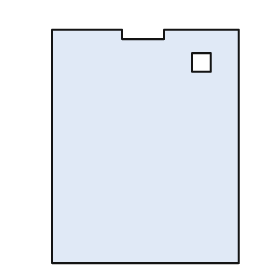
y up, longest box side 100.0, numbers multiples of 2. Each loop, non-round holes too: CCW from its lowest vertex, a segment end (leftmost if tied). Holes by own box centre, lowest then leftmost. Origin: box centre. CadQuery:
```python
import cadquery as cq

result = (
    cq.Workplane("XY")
    .moveTo(-40.0, -50.0)
    .lineTo(40.0, -50.0)
    .lineTo(40.0, 50.0)
    .lineTo(8.0, 50.0)
    .lineTo(8.0, 46.0)
    .lineTo(-10.0, 46.0)
    .lineTo(-10.0, 50.0)
    .lineTo(-40.0, 50.0)
    .close()
    .moveTo(20.0, 32.0)
    .lineTo(28.0, 32.0)
    .lineTo(28.0, 40.0)
    .lineTo(20.0, 40.0)
    .close()
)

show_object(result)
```